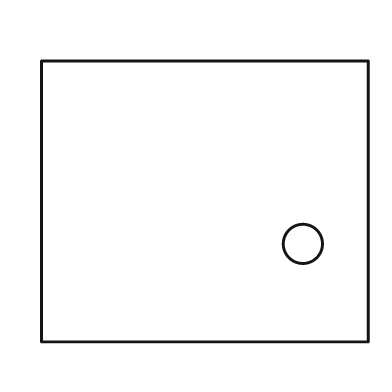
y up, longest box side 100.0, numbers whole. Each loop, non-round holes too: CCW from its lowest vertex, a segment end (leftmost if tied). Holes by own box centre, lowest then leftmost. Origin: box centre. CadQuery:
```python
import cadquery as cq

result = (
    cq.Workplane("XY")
    .moveTo(-50.0, -43.0)
    .lineTo(50.0, -43.0)
    .lineTo(50.0, 43.0)
    .lineTo(-50.0, 43.0)
    .close()
    .moveTo(30.0, -13.0)
    .circle(6.0)
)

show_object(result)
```